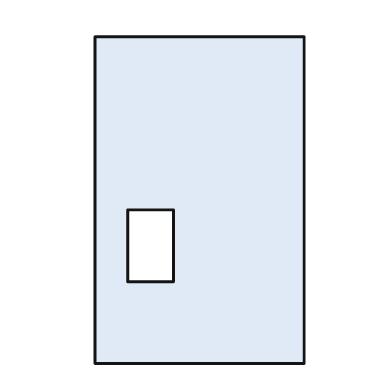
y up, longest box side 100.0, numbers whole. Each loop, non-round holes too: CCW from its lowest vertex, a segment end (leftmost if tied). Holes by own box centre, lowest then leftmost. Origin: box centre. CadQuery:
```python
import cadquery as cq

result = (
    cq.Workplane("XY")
    .moveTo(-32.0, -50.0)
    .lineTo(32.0, -50.0)
    .lineTo(32.0, 50.0)
    .lineTo(-32.0, 50.0)
    .close()
    .moveTo(-22.0, -25.0)
    .lineTo(-8.0, -25.0)
    .lineTo(-8.0, -3.0)
    .lineTo(-22.0, -3.0)
    .close()
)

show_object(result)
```